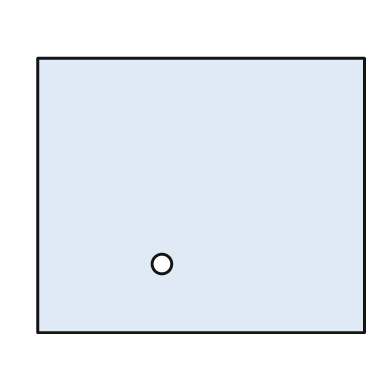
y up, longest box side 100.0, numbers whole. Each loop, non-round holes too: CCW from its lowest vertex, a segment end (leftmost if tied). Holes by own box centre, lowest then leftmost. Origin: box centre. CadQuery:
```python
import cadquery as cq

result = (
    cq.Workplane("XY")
    .moveTo(-50.0, -42.0)
    .lineTo(50.0, -42.0)
    .lineTo(50.0, 42.0)
    .lineTo(-50.0, 42.0)
    .close()
    .moveTo(-12.0, -21.0)
    .circle(3.0)
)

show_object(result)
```